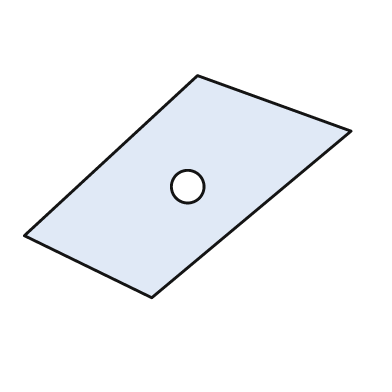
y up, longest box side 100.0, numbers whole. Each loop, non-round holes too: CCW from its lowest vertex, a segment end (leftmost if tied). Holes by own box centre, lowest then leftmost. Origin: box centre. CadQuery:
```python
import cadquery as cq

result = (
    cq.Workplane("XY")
    .moveTo(-11.0, -34.0)
    .lineTo(50.0, 17.0)
    .lineTo(3.0, 34.0)
    .lineTo(-50.0, -15.0)
    .close()
    .moveTo(0.0, 0.0)
    .circle(5.0)
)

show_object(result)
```